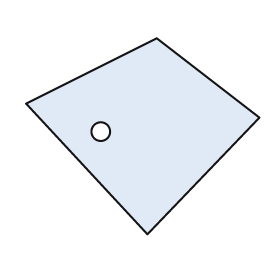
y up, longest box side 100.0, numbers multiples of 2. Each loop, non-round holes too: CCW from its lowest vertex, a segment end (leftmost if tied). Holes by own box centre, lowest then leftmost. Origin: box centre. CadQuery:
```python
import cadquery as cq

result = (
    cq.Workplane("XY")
    .moveTo(2.0, -42.0)
    .lineTo(50.0, 8.0)
    .lineTo(6.0, 42.0)
    .lineTo(-50.0, 14.0)
    .close()
    .moveTo(-18.0, 2.0)
    .circle(4.0)
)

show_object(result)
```